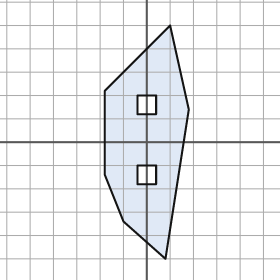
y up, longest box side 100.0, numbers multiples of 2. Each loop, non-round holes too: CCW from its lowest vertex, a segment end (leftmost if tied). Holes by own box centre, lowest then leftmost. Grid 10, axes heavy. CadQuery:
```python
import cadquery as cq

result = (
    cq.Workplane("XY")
    .moveTo(8.0, -50.0)
    .lineTo(18.0, 14.0)
    .lineTo(10.0, 50.0)
    .lineTo(-18.0, 22.0)
    .lineTo(-18.0, -14.0)
    .lineTo(-10.0, -34.0)
    .close()
    .moveTo(-4.0, -18.0)
    .lineTo(4.0, -18.0)
    .lineTo(4.0, -10.0)
    .lineTo(-4.0, -10.0)
    .close()
    .moveTo(-4.0, 12.0)
    .lineTo(4.0, 12.0)
    .lineTo(4.0, 20.0)
    .lineTo(-4.0, 20.0)
    .close()
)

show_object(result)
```